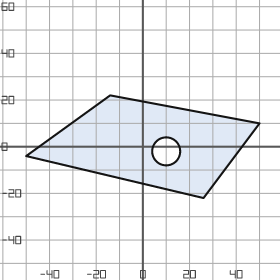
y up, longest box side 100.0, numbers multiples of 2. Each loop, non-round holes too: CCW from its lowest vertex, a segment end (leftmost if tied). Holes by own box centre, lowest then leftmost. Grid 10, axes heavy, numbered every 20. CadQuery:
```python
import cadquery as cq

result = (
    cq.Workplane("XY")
    .moveTo(26.0, -22.0)
    .lineTo(50.0, 10.0)
    .lineTo(-14.0, 22.0)
    .lineTo(-50.0, -4.0)
    .close()
    .moveTo(10.0, -2.0)
    .circle(6.0)
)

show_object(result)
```